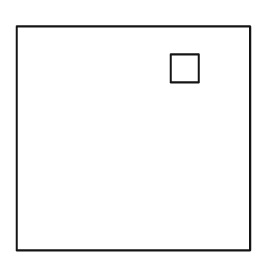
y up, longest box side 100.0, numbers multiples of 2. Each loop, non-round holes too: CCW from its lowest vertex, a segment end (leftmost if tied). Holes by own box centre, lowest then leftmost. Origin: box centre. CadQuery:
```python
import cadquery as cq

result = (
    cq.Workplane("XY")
    .moveTo(-50.0, -48.0)
    .lineTo(50.0, -48.0)
    .lineTo(50.0, 48.0)
    .lineTo(-50.0, 48.0)
    .close()
    .moveTo(16.0, 24.0)
    .lineTo(28.0, 24.0)
    .lineTo(28.0, 36.0)
    .lineTo(16.0, 36.0)
    .close()
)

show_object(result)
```